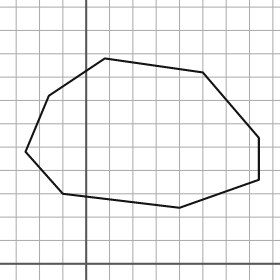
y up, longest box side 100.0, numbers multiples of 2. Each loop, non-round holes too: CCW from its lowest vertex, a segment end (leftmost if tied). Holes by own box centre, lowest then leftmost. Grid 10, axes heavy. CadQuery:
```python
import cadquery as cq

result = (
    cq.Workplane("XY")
    .moveTo(40.0, 24.0)
    .lineTo(74.0, 36.0)
    .lineTo(74.0, 54.0)
    .lineTo(50.0, 82.0)
    .lineTo(8.0, 88.0)
    .lineTo(-16.0, 72.0)
    .lineTo(-26.0, 48.0)
    .lineTo(-10.0, 30.0)
    .close()
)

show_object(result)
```